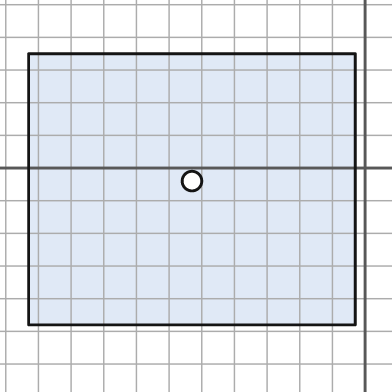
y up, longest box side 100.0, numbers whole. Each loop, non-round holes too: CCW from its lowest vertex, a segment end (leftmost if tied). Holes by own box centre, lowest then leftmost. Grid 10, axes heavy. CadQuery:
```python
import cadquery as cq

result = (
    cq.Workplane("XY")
    .moveTo(-103.0, -48.0)
    .lineTo(-3.0, -48.0)
    .lineTo(-3.0, 35.0)
    .lineTo(-103.0, 35.0)
    .close()
    .moveTo(-53.0, -4.0)
    .circle(3.0)
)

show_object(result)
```